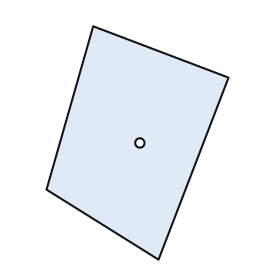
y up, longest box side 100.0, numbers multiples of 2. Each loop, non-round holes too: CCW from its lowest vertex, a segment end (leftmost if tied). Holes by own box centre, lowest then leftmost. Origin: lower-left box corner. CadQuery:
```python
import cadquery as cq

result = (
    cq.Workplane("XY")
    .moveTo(48.0, 0.0)
    .lineTo(78.0, 78.0)
    .lineTo(20.0, 100.0)
    .lineTo(0.0, 30.0)
    .close()
    .moveTo(40.0, 50.0)
    .circle(2.0)
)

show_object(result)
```